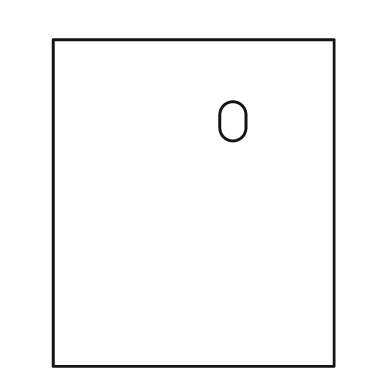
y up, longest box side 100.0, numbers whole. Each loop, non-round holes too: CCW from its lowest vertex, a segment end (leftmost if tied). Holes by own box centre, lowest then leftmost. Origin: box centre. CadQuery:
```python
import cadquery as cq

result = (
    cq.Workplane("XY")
    .moveTo(-43.0, -50.0)
    .lineTo(43.0, -50.0)
    .lineTo(43.0, 50.0)
    .lineTo(-43.0, 50.0)
    .close()
    .moveTo(8.0, 23.0)
    .threePointArc((12.0, 19.0), (16.0, 23.0))
    .lineTo(16.0, 27.0)
    .threePointArc((12.0, 31.0), (8.0, 27.0))
    .close()
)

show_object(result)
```